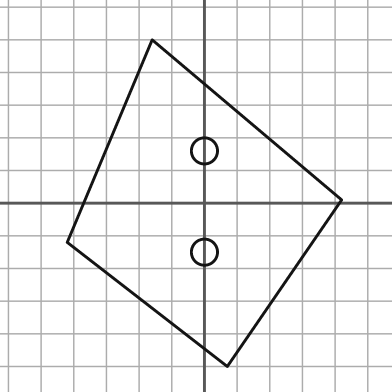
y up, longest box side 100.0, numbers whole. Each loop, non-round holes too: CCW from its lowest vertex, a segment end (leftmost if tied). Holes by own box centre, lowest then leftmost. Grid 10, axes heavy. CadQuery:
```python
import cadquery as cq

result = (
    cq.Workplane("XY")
    .moveTo(7.0, -50.0)
    .lineTo(42.0, 1.0)
    .lineTo(-16.0, 50.0)
    .lineTo(-42.0, -12.0)
    .close()
    .moveTo(0.0, -15.0)
    .circle(4.0)
    .moveTo(0.0, 16.0)
    .circle(4.0)
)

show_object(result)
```